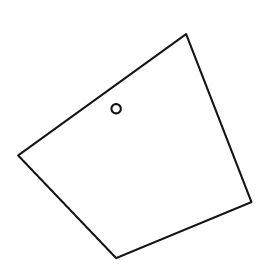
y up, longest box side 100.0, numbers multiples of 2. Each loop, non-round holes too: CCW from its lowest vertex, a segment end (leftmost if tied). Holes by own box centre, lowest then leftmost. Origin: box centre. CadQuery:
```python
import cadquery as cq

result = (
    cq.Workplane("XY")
    .moveTo(-8.0, -48.0)
    .lineTo(50.0, -24.0)
    .lineTo(22.0, 48.0)
    .lineTo(-50.0, -4.0)
    .close()
    .moveTo(-8.0, 16.0)
    .circle(2.0)
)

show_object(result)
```